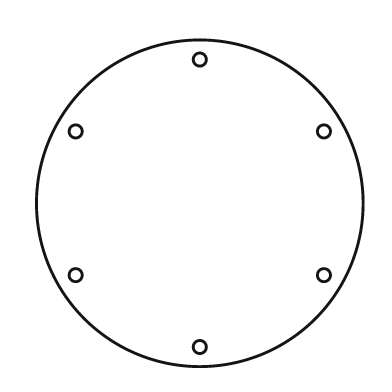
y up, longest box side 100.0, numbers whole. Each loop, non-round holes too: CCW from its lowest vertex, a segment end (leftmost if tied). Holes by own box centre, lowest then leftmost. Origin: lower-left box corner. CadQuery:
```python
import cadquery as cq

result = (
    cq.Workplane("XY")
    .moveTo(50.0, 50.0)
    .circle(50.0)
    .moveTo(50.0, 6.0)
    .circle(2.0)
    .moveTo(12.0, 28.0)
    .circle(2.0)
    .moveTo(88.0, 28.0)
    .circle(2.0)
    .moveTo(12.0, 72.0)
    .circle(2.0)
    .moveTo(88.0, 72.0)
    .circle(2.0)
    .moveTo(50.0, 94.0)
    .circle(2.0)
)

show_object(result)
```